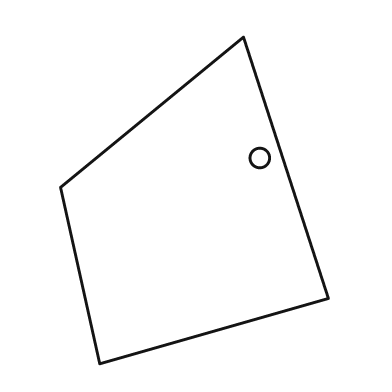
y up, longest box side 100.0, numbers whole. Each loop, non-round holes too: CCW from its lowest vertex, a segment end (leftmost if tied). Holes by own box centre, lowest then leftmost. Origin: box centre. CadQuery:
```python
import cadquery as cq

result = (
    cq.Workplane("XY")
    .moveTo(-29.0, -50.0)
    .lineTo(41.0, -30.0)
    .lineTo(15.0, 50.0)
    .lineTo(-41.0, 4.0)
    .close()
    .moveTo(20.0, 13.0)
    .circle(3.0)
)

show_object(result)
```